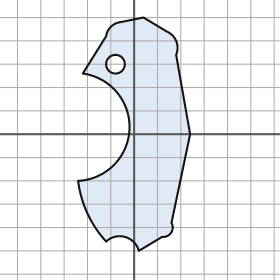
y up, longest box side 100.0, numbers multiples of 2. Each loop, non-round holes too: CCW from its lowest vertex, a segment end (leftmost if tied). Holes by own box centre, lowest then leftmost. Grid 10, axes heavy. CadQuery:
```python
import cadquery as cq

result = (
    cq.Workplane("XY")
    .moveTo(2.0, -50.0)
    .lineTo(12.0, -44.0)
    .threePointArc((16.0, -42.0), (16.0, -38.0))
    .lineTo(24.0, 0.0)
    .lineTo(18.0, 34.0)
    .threePointArc((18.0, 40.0), (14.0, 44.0))
    .lineTo(4.0, 50.0)
    .lineTo(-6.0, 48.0)
    .threePointArc((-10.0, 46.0), (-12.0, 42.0))
    .lineTo(-22.0, 26.0)
    .threePointArc((-2.0, 2.0), (-24.0, -20.0))
    .threePointArc((-20.0, -34.0), (-12.0, -46.0))
    .threePointArc((-4.0, -44.0), (2.0, -50.0))
    .close()
    .moveTo(-8.0, 30.0)
    .circle(4.0)
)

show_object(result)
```